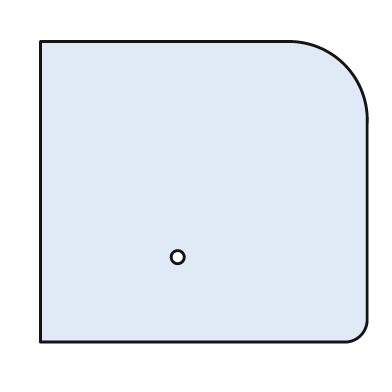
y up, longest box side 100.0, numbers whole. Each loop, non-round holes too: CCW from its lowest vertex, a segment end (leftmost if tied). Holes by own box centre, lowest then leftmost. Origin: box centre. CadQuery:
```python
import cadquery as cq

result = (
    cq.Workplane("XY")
    .moveTo(-50.0, -46.0)
    .lineTo(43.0, -46.0)
    .threePointArc((48.0, -44.0), (50.0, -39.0))
    .lineTo(50.0, 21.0)
    .threePointArc((43.0, 39.0), (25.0, 46.0))
    .lineTo(-50.0, 46.0)
    .close()
    .moveTo(-8.0, -20.0)
    .circle(2.0)
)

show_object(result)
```